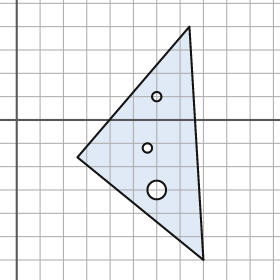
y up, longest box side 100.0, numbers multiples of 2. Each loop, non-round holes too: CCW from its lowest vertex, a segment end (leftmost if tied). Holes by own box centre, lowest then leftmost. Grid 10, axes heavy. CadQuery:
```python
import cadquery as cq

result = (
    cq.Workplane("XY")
    .moveTo(80.0, -60.0)
    .lineTo(74.0, 40.0)
    .lineTo(26.0, -16.0)
    .close()
    .moveTo(60.0, -30.0)
    .circle(4.0)
    .moveTo(56.0, -12.0)
    .circle(2.0)
    .moveTo(60.0, 10.0)
    .circle(2.0)
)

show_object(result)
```